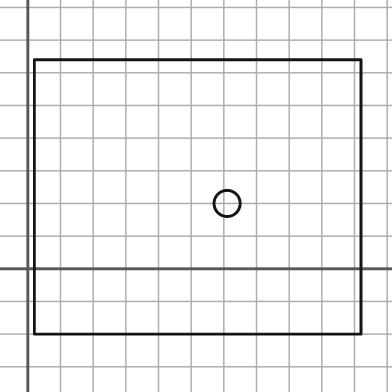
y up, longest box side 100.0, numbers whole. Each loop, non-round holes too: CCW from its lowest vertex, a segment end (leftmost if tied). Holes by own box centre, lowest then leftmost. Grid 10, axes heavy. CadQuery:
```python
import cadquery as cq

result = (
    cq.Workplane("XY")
    .moveTo(2.0, -20.0)
    .lineTo(102.0, -20.0)
    .lineTo(102.0, 64.0)
    .lineTo(2.0, 64.0)
    .close()
    .moveTo(61.0, 20.0)
    .circle(4.0)
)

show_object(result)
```